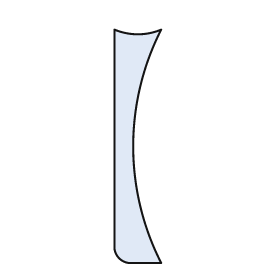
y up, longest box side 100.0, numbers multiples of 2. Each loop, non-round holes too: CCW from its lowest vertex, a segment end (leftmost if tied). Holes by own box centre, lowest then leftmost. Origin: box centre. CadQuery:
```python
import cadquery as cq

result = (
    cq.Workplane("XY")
    .moveTo(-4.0, -50.0)
    .lineTo(10.0, -50.0)
    .threePointArc((-2.0, 0.0), (10.0, 50.0))
    .threePointArc((0.0, 48.0), (-10.0, 50.0))
    .lineTo(-10.0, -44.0)
    .threePointArc((-8.0, -48.0), (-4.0, -50.0))
    .close()
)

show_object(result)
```